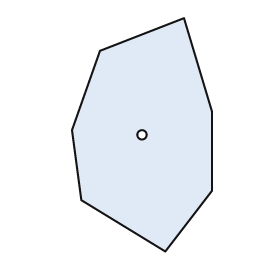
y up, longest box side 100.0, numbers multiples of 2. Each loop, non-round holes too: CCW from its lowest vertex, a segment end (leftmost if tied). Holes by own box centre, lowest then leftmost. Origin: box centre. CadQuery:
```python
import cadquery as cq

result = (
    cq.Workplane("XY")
    .moveTo(10.0, -50.0)
    .lineTo(30.0, -24.0)
    .lineTo(30.0, 10.0)
    .lineTo(18.0, 50.0)
    .lineTo(-18.0, 36.0)
    .lineTo(-30.0, 2.0)
    .lineTo(-26.0, -28.0)
    .close()
    .moveTo(0.0, 0.0)
    .circle(2.0)
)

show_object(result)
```